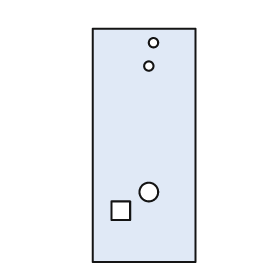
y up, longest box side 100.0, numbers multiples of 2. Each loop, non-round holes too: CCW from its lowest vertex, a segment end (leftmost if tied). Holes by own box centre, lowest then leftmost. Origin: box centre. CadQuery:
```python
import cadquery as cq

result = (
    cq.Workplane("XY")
    .moveTo(-22.0, -50.0)
    .lineTo(22.0, -50.0)
    .lineTo(22.0, 50.0)
    .lineTo(-22.0, 50.0)
    .close()
    .moveTo(-14.0, -32.0)
    .lineTo(-6.0, -32.0)
    .lineTo(-6.0, -24.0)
    .lineTo(-14.0, -24.0)
    .close()
    .moveTo(2.0, -20.0)
    .circle(4.0)
    .moveTo(2.0, 34.0)
    .circle(2.0)
    .moveTo(4.0, 44.0)
    .circle(2.0)
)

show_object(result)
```